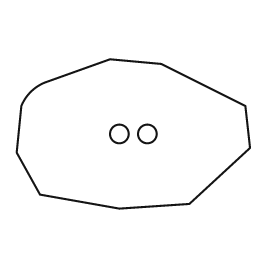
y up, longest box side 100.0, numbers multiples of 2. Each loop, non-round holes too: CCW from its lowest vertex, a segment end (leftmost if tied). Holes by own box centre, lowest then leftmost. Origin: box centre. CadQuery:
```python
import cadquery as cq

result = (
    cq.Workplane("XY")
    .moveTo(-6.0, -32.0)
    .lineTo(24.0, -30.0)
    .lineTo(50.0, -6.0)
    .lineTo(48.0, 12.0)
    .lineTo(12.0, 30.0)
    .lineTo(-10.0, 32.0)
    .lineTo(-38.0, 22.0)
    .threePointArc((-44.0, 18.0), (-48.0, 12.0))
    .lineTo(-50.0, -8.0)
    .lineTo(-40.0, -26.0)
    .close()
    .moveTo(-6.0, 0.0)
    .circle(4.0)
    .moveTo(6.0, 0.0)
    .circle(4.0)
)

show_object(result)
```